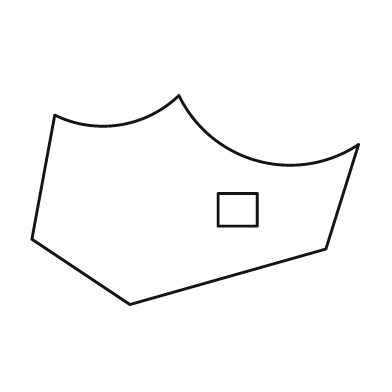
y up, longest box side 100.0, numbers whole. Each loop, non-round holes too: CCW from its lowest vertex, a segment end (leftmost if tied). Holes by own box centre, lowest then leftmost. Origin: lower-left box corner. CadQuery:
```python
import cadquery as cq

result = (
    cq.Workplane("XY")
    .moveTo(30.0, 0.0)
    .lineTo(90.0, 17.0)
    .lineTo(100.0, 49.0)
    .threePointArc((69.0, 44.0), (45.0, 64.0))
    .threePointArc((27.0, 55.0), (7.0, 58.0))
    .lineTo(0.0, 20.0)
    .close()
    .moveTo(57.0, 24.0)
    .lineTo(69.0, 24.0)
    .lineTo(69.0, 34.0)
    .lineTo(57.0, 34.0)
    .close()
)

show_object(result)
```